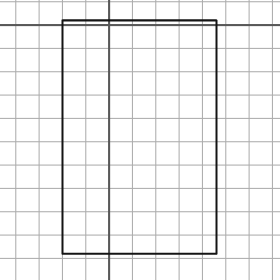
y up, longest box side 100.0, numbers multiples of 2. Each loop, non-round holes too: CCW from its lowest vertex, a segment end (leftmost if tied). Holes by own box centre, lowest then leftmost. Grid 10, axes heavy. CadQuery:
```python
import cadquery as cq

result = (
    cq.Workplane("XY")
    .moveTo(-20.0, -98.0)
    .lineTo(46.0, -98.0)
    .lineTo(46.0, 2.0)
    .lineTo(-20.0, 2.0)
    .close()
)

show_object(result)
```